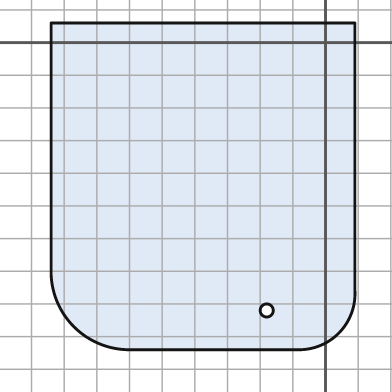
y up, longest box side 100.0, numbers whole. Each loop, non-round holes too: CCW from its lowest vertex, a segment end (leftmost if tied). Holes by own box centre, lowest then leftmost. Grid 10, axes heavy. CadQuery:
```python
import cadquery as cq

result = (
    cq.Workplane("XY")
    .moveTo(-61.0, -94.0)
    .lineTo(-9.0, -94.0)
    .threePointArc((4.0, -89.0), (9.0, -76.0))
    .lineTo(9.0, 6.0)
    .lineTo(-84.0, 6.0)
    .lineTo(-84.0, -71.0)
    .threePointArc((-77.0, -87.0), (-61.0, -94.0))
    .close()
    .moveTo(-18.0, -82.0)
    .circle(2.0)
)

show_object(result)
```